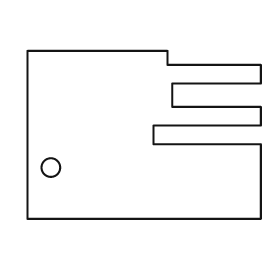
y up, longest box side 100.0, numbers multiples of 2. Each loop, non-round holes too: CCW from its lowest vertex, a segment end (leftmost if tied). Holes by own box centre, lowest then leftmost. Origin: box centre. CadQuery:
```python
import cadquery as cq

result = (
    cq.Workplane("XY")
    .moveTo(-50.0, -36.0)
    .lineTo(50.0, -36.0)
    .lineTo(50.0, -4.0)
    .lineTo(4.0, -4.0)
    .lineTo(4.0, 4.0)
    .lineTo(50.0, 4.0)
    .lineTo(50.0, 12.0)
    .lineTo(12.0, 12.0)
    .lineTo(12.0, 22.0)
    .lineTo(50.0, 22.0)
    .lineTo(50.0, 30.0)
    .lineTo(10.0, 30.0)
    .lineTo(10.0, 36.0)
    .lineTo(-50.0, 36.0)
    .close()
    .moveTo(-40.0, -14.0)
    .circle(4.0)
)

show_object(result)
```